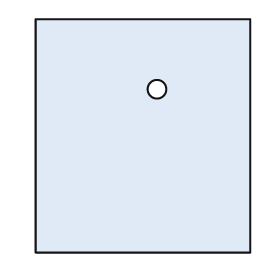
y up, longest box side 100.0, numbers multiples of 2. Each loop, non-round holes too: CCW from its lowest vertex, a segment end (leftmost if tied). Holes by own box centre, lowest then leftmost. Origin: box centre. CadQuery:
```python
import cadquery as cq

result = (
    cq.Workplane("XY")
    .moveTo(-46.0, -50.0)
    .lineTo(46.0, -50.0)
    .lineTo(46.0, 50.0)
    .lineTo(-46.0, 50.0)
    .close()
    .moveTo(6.0, 20.0)
    .circle(4.0)
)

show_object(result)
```